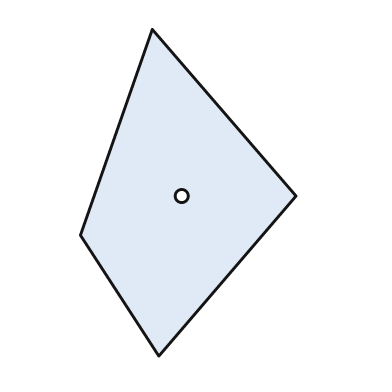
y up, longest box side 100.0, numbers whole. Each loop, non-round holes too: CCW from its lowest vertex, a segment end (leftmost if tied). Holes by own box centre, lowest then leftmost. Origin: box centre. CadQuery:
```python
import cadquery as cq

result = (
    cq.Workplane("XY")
    .moveTo(-9.0, -50.0)
    .lineTo(33.0, -1.0)
    .lineTo(-11.0, 50.0)
    .lineTo(-33.0, -13.0)
    .close()
    .moveTo(-2.0, -1.0)
    .circle(2.0)
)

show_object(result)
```